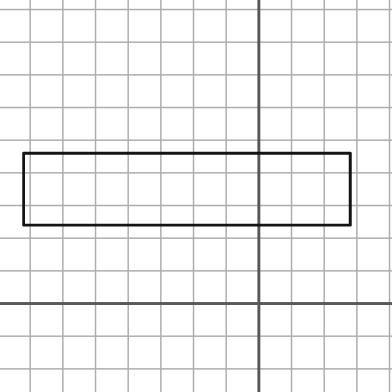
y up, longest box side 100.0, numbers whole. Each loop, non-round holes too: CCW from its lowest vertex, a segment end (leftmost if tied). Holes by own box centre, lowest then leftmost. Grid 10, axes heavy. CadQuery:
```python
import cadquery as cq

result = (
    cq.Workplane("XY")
    .moveTo(-72.0, 24.0)
    .lineTo(28.0, 24.0)
    .lineTo(28.0, 46.0)
    .lineTo(-72.0, 46.0)
    .close()
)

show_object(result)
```